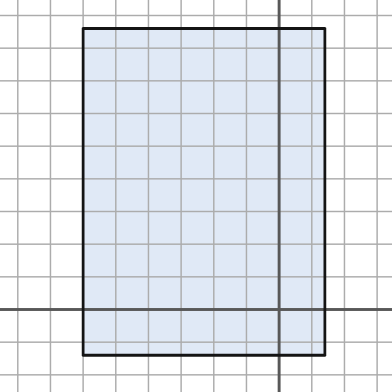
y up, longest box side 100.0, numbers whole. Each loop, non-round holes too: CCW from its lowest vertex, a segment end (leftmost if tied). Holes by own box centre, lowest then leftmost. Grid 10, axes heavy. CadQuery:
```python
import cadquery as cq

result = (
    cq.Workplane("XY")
    .moveTo(-60.0, -14.0)
    .lineTo(14.0, -14.0)
    .lineTo(14.0, 86.0)
    .lineTo(-60.0, 86.0)
    .close()
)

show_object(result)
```